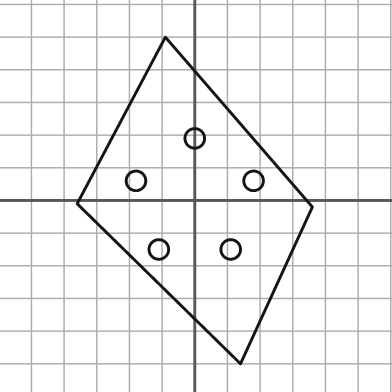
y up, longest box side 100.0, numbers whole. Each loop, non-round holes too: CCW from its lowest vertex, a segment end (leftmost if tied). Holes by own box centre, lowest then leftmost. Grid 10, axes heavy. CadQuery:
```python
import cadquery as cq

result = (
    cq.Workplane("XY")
    .moveTo(14.0, -50.0)
    .lineTo(36.0, -2.0)
    .lineTo(-9.0, 50.0)
    .lineTo(-36.0, -1.0)
    .close()
    .moveTo(-11.0, -15.0)
    .circle(3.0)
    .moveTo(11.0, -15.0)
    .circle(3.0)
    .moveTo(-18.0, 6.0)
    .circle(3.0)
    .moveTo(18.0, 6.0)
    .circle(3.0)
    .moveTo(0.0, 19.0)
    .circle(3.0)
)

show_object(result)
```